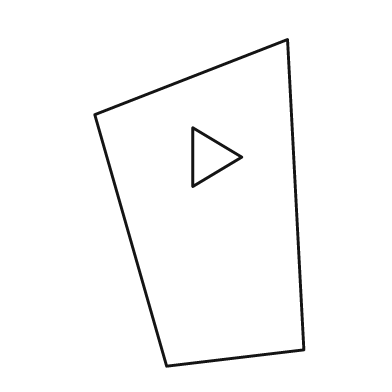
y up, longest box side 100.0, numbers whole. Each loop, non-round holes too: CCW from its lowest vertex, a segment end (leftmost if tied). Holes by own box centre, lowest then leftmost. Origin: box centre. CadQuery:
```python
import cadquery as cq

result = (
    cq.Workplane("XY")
    .moveTo(-10.0, -50.0)
    .lineTo(32.0, -45.0)
    .lineTo(27.0, 50.0)
    .lineTo(-32.0, 27.0)
    .close()
    .moveTo(-2.0, 5.0)
    .lineTo(13.0, 14.0)
    .lineTo(-2.0, 23.0)
    .close()
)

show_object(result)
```